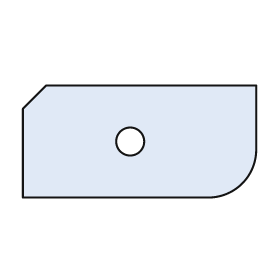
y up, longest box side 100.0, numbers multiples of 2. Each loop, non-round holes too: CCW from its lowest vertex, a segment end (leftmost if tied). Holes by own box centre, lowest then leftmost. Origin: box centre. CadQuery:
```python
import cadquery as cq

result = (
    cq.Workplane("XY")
    .moveTo(-50.0, -24.0)
    .lineTo(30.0, -24.0)
    .threePointArc((44.0, -18.0), (50.0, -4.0))
    .lineTo(50.0, 24.0)
    .lineTo(-40.0, 24.0)
    .lineTo(-50.0, 14.0)
    .close()
    .moveTo(-4.0, 0.0)
    .circle(6.0)
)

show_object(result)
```